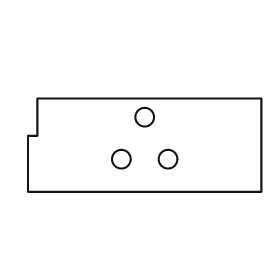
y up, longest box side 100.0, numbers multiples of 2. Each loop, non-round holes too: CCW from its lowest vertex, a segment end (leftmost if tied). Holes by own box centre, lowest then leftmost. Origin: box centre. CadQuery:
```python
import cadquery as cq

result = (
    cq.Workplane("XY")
    .moveTo(-50.0, -20.0)
    .lineTo(50.0, -20.0)
    .lineTo(50.0, 20.0)
    .lineTo(-46.0, 20.0)
    .lineTo(-46.0, 4.0)
    .lineTo(-50.0, 4.0)
    .close()
    .moveTo(-10.0, -6.0)
    .circle(4.0)
    .moveTo(10.0, -6.0)
    .circle(4.0)
    .moveTo(0.0, 12.0)
    .circle(4.0)
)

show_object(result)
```